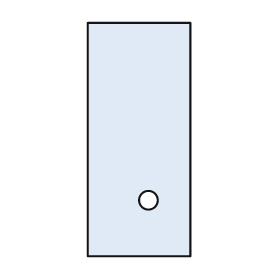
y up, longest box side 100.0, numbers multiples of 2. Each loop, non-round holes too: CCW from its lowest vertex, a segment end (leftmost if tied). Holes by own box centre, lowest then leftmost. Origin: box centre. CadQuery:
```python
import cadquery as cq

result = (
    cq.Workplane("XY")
    .moveTo(-22.0, -50.0)
    .lineTo(22.0, -50.0)
    .lineTo(22.0, 50.0)
    .lineTo(-22.0, 50.0)
    .close()
    .moveTo(4.0, -26.0)
    .circle(4.0)
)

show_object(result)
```